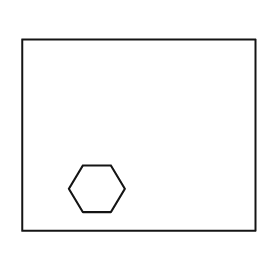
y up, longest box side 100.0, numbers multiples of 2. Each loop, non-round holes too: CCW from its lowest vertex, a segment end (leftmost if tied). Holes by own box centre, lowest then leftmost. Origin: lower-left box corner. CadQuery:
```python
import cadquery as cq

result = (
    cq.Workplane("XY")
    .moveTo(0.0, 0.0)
    .lineTo(100.0, 0.0)
    .lineTo(100.0, 82.0)
    .lineTo(0.0, 82.0)
    .close()
    .moveTo(26.0, 8.0)
    .lineTo(38.0, 8.0)
    .lineTo(44.0, 18.0)
    .lineTo(38.0, 28.0)
    .lineTo(26.0, 28.0)
    .lineTo(20.0, 18.0)
    .close()
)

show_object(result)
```